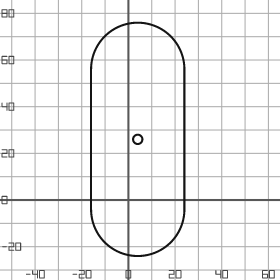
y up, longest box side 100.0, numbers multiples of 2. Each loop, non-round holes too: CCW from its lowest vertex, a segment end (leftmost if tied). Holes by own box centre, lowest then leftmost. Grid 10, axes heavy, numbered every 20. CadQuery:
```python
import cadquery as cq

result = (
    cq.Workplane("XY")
    .moveTo(-16.0, -4.0)
    .threePointArc((4.0, -24.0), (24.0, -4.0))
    .lineTo(24.0, 56.0)
    .threePointArc((4.0, 76.0), (-16.0, 56.0))
    .close()
    .moveTo(4.0, 26.0)
    .circle(2.0)
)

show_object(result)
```